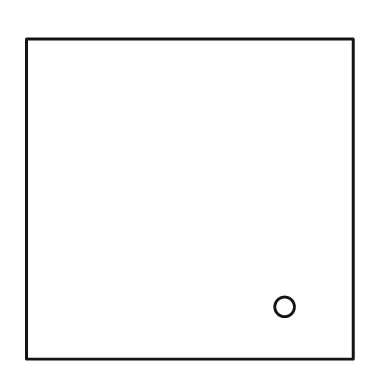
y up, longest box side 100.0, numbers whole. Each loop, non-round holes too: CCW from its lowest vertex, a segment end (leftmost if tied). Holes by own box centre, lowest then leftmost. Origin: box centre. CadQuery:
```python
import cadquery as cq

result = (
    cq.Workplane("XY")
    .moveTo(-50.0, -49.0)
    .lineTo(50.0, -49.0)
    .lineTo(50.0, 49.0)
    .lineTo(-50.0, 49.0)
    .close()
    .moveTo(29.0, -33.0)
    .circle(3.0)
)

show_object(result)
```